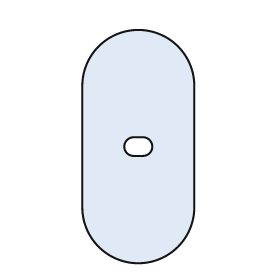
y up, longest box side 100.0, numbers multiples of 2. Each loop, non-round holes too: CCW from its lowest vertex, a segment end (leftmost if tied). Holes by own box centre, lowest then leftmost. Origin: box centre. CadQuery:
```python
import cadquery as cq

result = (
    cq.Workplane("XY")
    .moveTo(-24.0, -26.0)
    .threePointArc((0.0, -50.0), (24.0, -26.0))
    .lineTo(24.0, 26.0)
    .threePointArc((0.0, 50.0), (-24.0, 26.0))
    .close()
    .moveTo(-2.0, -4.0)
    .lineTo(2.0, -4.0)
    .threePointArc((6.0, 0.0), (2.0, 4.0))
    .lineTo(-2.0, 4.0)
    .threePointArc((-6.0, 0.0), (-2.0, -4.0))
    .close()
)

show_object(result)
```